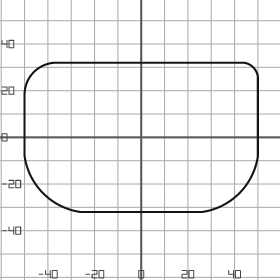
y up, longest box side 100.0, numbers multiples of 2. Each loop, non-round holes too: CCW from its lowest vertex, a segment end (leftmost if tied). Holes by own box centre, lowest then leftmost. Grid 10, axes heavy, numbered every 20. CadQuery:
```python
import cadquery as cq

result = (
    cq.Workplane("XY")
    .moveTo(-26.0, -32.0)
    .lineTo(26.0, -32.0)
    .threePointArc((42.0, -24.0), (50.0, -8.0))
    .lineTo(50.0, 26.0)
    .threePointArc((48.0, 30.0), (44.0, 32.0))
    .lineTo(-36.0, 32.0)
    .threePointArc((-46.0, 28.0), (-50.0, 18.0))
    .lineTo(-50.0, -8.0)
    .threePointArc((-42.0, -24.0), (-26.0, -32.0))
    .close()
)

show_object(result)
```